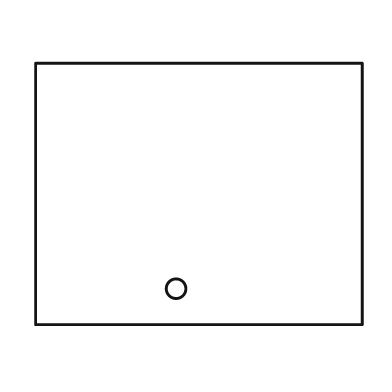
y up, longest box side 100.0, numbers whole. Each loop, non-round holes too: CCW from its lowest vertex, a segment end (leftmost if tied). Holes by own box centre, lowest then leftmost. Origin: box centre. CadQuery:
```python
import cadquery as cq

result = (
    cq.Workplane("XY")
    .moveTo(-50.0, -40.0)
    .lineTo(50.0, -40.0)
    .lineTo(50.0, 40.0)
    .lineTo(-50.0, 40.0)
    .close()
    .moveTo(-7.0, -29.0)
    .circle(3.0)
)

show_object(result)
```